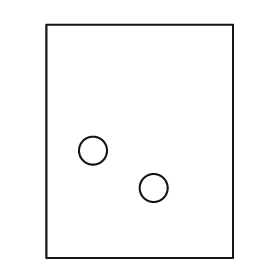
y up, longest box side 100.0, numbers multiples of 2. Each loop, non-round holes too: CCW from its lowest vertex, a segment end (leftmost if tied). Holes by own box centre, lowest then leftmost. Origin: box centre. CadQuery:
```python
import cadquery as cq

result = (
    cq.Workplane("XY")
    .moveTo(-40.0, -50.0)
    .lineTo(40.0, -50.0)
    .lineTo(40.0, 50.0)
    .lineTo(-40.0, 50.0)
    .close()
    .moveTo(6.0, -20.0)
    .circle(6.0)
    .moveTo(-20.0, -4.0)
    .circle(6.0)
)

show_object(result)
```